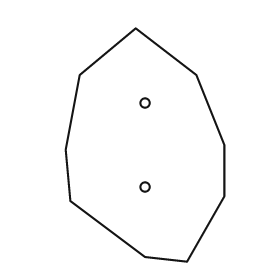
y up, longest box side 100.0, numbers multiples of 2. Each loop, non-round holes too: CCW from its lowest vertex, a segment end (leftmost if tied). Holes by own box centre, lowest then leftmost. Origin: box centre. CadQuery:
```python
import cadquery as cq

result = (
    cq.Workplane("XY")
    .moveTo(18.0, -50.0)
    .lineTo(34.0, -22.0)
    .lineTo(34.0, 0.0)
    .lineTo(22.0, 30.0)
    .lineTo(-4.0, 50.0)
    .lineTo(-28.0, 30.0)
    .lineTo(-34.0, -2.0)
    .lineTo(-32.0, -24.0)
    .lineTo(0.0, -48.0)
    .close()
    .moveTo(0.0, -18.0)
    .circle(2.0)
    .moveTo(0.0, 18.0)
    .circle(2.0)
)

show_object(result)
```